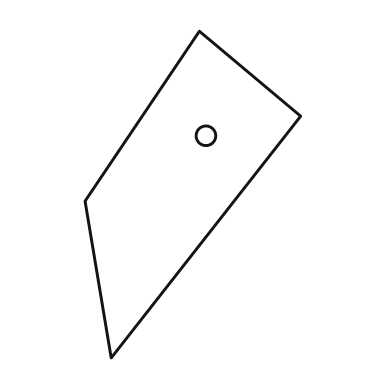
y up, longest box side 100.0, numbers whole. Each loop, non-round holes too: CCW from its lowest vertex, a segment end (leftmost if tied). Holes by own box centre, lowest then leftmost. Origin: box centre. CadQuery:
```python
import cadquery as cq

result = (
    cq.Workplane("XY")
    .moveTo(-25.0, -50.0)
    .lineTo(33.0, 24.0)
    .lineTo(2.0, 50.0)
    .lineTo(-33.0, -2.0)
    .close()
    .moveTo(4.0, 18.0)
    .circle(3.0)
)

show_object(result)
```